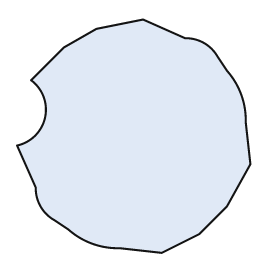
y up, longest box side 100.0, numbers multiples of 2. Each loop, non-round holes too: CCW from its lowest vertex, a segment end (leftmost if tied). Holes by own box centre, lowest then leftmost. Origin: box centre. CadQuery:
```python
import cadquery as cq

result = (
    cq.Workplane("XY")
    .moveTo(12.0, -50.0)
    .lineTo(28.0, -42.0)
    .lineTo(40.0, -30.0)
    .lineTo(50.0, -12.0)
    .lineTo(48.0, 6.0)
    .threePointArc((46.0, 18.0), (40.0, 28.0))
    .lineTo(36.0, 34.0)
    .threePointArc((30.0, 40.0), (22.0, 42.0))
    .lineTo(4.0, 50.0)
    .lineTo(-16.0, 46.0)
    .lineTo(-30.0, 38.0)
    .lineTo(-44.0, 24.0)
    .threePointArc((-38.0, 8.0), (-50.0, -4.0))
    .lineTo(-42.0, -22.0)
    .threePointArc((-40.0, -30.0), (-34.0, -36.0))
    .lineTo(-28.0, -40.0)
    .threePointArc((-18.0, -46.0), (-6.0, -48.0))
    .close()
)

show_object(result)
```